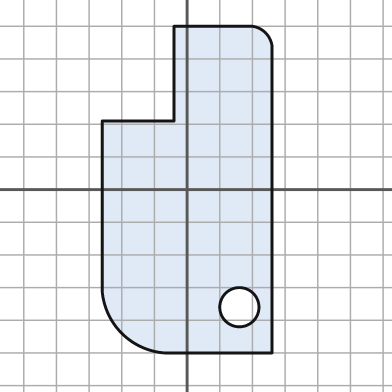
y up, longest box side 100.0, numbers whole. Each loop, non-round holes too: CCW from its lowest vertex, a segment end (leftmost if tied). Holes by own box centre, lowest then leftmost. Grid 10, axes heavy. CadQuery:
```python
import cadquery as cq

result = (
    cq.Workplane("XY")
    .moveTo(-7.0, -50.0)
    .lineTo(26.0, -50.0)
    .lineTo(26.0, 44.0)
    .threePointArc((24.0, 48.0), (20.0, 50.0))
    .lineTo(-4.0, 50.0)
    .lineTo(-4.0, 21.0)
    .lineTo(-26.0, 21.0)
    .lineTo(-26.0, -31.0)
    .threePointArc((-20.0, -44.0), (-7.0, -50.0))
    .close()
    .moveTo(16.0, -36.0)
    .circle(6.0)
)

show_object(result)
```